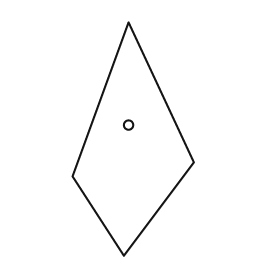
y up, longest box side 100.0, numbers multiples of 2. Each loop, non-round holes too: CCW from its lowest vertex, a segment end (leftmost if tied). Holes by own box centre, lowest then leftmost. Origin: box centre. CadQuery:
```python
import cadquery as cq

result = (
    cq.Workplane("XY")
    .moveTo(-4.0, -50.0)
    .lineTo(26.0, -10.0)
    .lineTo(-2.0, 50.0)
    .lineTo(-26.0, -16.0)
    .close()
    .moveTo(-2.0, 6.0)
    .circle(2.0)
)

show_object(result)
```